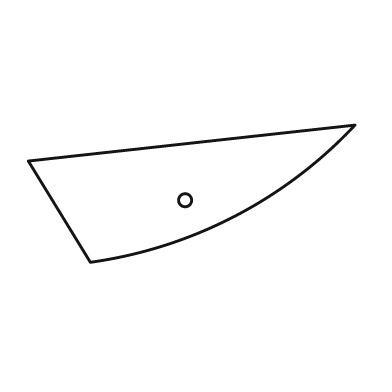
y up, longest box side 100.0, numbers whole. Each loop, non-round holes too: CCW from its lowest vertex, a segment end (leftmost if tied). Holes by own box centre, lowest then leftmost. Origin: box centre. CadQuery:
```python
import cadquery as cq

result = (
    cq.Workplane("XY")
    .moveTo(-31.0, -21.0)
    .threePointArc((13.0, -7.0), (50.0, 21.0))
    .lineTo(-50.0, 10.0)
    .close()
    .moveTo(-2.0, -2.0)
    .circle(2.0)
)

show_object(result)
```